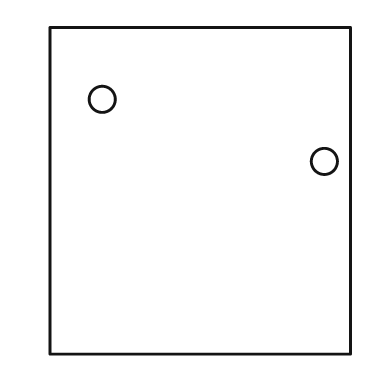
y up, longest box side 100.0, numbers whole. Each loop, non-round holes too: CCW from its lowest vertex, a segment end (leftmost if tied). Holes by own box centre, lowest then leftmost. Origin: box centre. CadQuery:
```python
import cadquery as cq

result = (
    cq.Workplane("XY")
    .moveTo(-46.0, -50.0)
    .lineTo(46.0, -50.0)
    .lineTo(46.0, 50.0)
    .lineTo(-46.0, 50.0)
    .close()
    .moveTo(38.0, 9.0)
    .circle(4.0)
    .moveTo(-30.0, 28.0)
    .circle(4.0)
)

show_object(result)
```